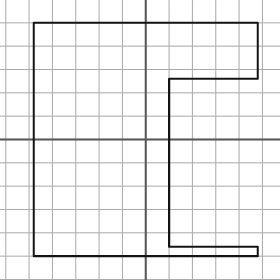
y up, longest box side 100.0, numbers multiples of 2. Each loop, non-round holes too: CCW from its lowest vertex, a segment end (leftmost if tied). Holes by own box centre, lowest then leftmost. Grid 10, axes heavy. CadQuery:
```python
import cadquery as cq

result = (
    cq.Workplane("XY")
    .moveTo(-48.0, -50.0)
    .lineTo(48.0, -50.0)
    .lineTo(48.0, -46.0)
    .lineTo(10.0, -46.0)
    .lineTo(10.0, 26.0)
    .lineTo(48.0, 26.0)
    .lineTo(48.0, 50.0)
    .lineTo(-48.0, 50.0)
    .close()
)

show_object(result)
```